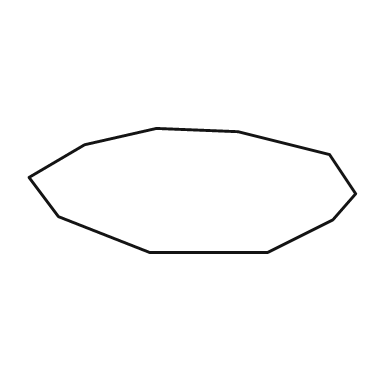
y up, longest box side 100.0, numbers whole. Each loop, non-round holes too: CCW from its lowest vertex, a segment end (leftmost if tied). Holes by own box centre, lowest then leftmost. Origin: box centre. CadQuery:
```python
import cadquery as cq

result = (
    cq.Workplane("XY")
    .moveTo(-13.0, -19.0)
    .lineTo(23.0, -19.0)
    .lineTo(43.0, -9.0)
    .lineTo(50.0, -1.0)
    .lineTo(42.0, 11.0)
    .lineTo(14.0, 18.0)
    .lineTo(-11.0, 19.0)
    .lineTo(-33.0, 14.0)
    .lineTo(-50.0, 4.0)
    .lineTo(-41.0, -8.0)
    .close()
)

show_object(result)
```